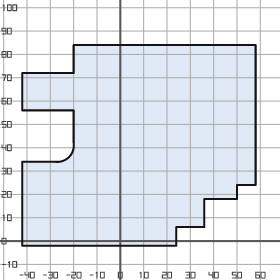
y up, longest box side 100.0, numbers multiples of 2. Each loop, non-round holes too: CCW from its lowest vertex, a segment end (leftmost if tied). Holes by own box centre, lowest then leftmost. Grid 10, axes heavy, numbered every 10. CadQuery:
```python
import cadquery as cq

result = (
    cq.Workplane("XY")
    .moveTo(-42.0, -2.0)
    .lineTo(24.0, -2.0)
    .lineTo(24.0, 6.0)
    .lineTo(36.0, 6.0)
    .lineTo(36.0, 18.0)
    .lineTo(50.0, 18.0)
    .lineTo(50.0, 24.0)
    .lineTo(58.0, 24.0)
    .lineTo(58.0, 84.0)
    .lineTo(-20.0, 84.0)
    .lineTo(-20.0, 72.0)
    .lineTo(-42.0, 72.0)
    .lineTo(-42.0, 56.0)
    .lineTo(-20.0, 56.0)
    .lineTo(-20.0, 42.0)
    .threePointArc((-22.0, 36.0), (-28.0, 34.0))
    .lineTo(-42.0, 34.0)
    .close()
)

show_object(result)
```